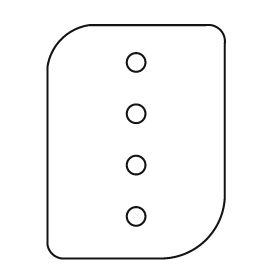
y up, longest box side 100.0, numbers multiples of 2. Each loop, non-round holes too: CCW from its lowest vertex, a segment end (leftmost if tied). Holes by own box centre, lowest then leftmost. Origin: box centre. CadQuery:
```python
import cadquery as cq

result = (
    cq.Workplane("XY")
    .moveTo(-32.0, -50.0)
    .lineTo(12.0, -50.0)
    .threePointArc((30.0, -42.0), (38.0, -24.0))
    .lineTo(38.0, 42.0)
    .threePointArc((36.0, 48.0), (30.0, 50.0))
    .lineTo(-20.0, 50.0)
    .threePointArc((-32.0, 44.0), (-38.0, 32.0))
    .lineTo(-38.0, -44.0)
    .threePointArc((-36.0, -48.0), (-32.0, -50.0))
    .close()
    .moveTo(0.0, -32.0)
    .circle(4.0)
    .moveTo(0.0, -10.0)
    .circle(4.0)
    .moveTo(0.0, 12.0)
    .circle(4.0)
    .moveTo(0.0, 34.0)
    .circle(4.0)
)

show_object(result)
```